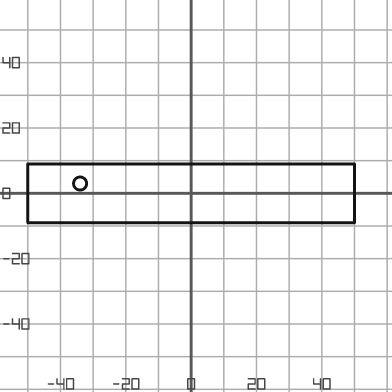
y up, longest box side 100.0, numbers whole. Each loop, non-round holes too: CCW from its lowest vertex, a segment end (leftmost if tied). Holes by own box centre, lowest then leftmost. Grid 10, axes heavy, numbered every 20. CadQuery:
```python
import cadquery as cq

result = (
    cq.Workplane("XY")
    .moveTo(-50.0, -9.0)
    .lineTo(50.0, -9.0)
    .lineTo(50.0, 9.0)
    .lineTo(-50.0, 9.0)
    .close()
    .moveTo(-34.0, 3.0)
    .circle(2.0)
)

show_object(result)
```